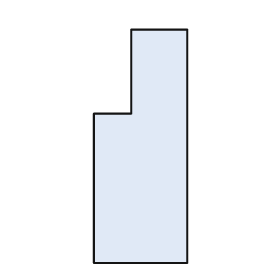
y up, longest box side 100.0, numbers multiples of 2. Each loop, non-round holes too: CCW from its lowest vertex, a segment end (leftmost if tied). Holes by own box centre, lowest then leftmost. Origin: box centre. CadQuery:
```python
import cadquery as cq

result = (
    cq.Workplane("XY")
    .moveTo(-20.0, -50.0)
    .lineTo(20.0, -50.0)
    .lineTo(20.0, 50.0)
    .lineTo(-4.0, 50.0)
    .lineTo(-4.0, 14.0)
    .lineTo(-20.0, 14.0)
    .close()
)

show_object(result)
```